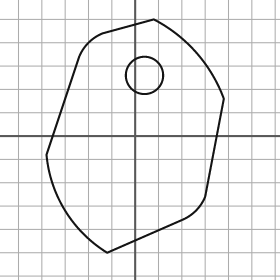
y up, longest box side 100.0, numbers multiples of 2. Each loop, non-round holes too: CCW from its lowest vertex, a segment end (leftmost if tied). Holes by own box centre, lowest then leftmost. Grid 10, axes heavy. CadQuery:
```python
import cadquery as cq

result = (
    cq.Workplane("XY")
    .moveTo(-12.0, -50.0)
    .lineTo(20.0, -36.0)
    .threePointArc((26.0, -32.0), (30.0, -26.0))
    .lineTo(38.0, 16.0)
    .threePointArc((26.0, 36.0), (8.0, 50.0))
    .lineTo(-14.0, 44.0)
    .threePointArc((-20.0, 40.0), (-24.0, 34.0))
    .lineTo(-38.0, -8.0)
    .threePointArc((-30.0, -32.0), (-12.0, -50.0))
    .close()
    .moveTo(4.0, 26.0)
    .circle(8.0)
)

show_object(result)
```